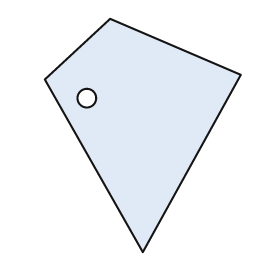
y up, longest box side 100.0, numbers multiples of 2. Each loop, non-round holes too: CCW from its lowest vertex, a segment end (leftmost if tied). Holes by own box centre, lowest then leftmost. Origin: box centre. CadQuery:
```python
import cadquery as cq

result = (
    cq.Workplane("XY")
    .moveTo(0.0, -50.0)
    .lineTo(42.0, 26.0)
    .lineTo(-14.0, 50.0)
    .lineTo(-42.0, 24.0)
    .close()
    .moveTo(-24.0, 16.0)
    .circle(4.0)
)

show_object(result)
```